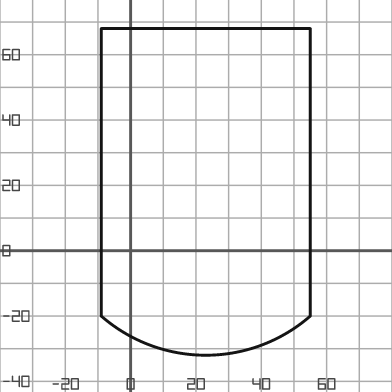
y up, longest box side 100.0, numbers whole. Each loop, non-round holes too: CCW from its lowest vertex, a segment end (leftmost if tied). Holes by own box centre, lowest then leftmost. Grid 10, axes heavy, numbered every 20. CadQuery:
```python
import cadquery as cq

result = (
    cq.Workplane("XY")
    .moveTo(-9.0, -20.0)
    .threePointArc((23.0, -32.0), (55.0, -20.0))
    .lineTo(55.0, 68.0)
    .lineTo(-9.0, 68.0)
    .close()
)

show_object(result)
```